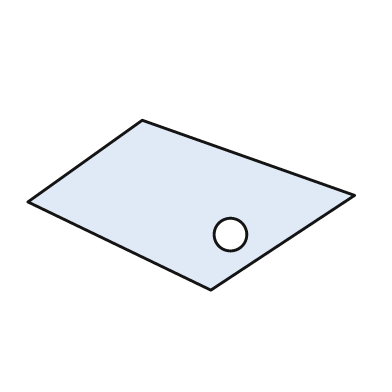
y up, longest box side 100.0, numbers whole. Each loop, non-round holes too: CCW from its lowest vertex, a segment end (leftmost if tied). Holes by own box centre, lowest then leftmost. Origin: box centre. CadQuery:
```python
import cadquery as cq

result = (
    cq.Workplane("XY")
    .moveTo(6.0, -26.0)
    .lineTo(50.0, 3.0)
    .lineTo(-15.0, 26.0)
    .lineTo(-50.0, 1.0)
    .close()
    .moveTo(12.0, -9.0)
    .circle(5.0)
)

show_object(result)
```